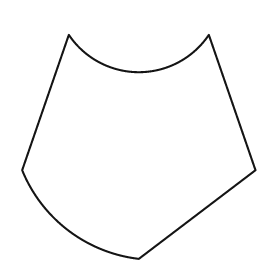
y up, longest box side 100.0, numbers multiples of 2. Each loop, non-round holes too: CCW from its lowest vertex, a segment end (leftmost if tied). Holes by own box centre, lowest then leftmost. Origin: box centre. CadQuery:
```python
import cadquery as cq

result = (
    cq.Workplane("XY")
    .moveTo(0.0, -48.0)
    .lineTo(50.0, -10.0)
    .lineTo(30.0, 48.0)
    .threePointArc((0.0, 32.0), (-30.0, 48.0))
    .lineTo(-50.0, -10.0)
    .threePointArc((-30.0, -36.0), (0.0, -48.0))
    .close()
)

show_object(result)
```